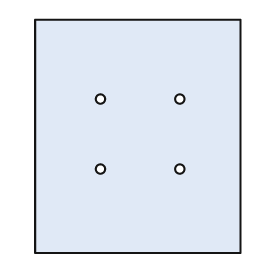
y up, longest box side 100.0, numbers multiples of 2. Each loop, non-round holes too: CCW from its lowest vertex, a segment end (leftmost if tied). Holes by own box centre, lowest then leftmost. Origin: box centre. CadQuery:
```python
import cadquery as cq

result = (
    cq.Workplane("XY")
    .moveTo(-44.0, -50.0)
    .lineTo(44.0, -50.0)
    .lineTo(44.0, 50.0)
    .lineTo(-44.0, 50.0)
    .close()
    .moveTo(-16.0, -14.0)
    .circle(2.0)
    .moveTo(18.0, -14.0)
    .circle(2.0)
    .moveTo(-16.0, 16.0)
    .circle(2.0)
    .moveTo(18.0, 16.0)
    .circle(2.0)
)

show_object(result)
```